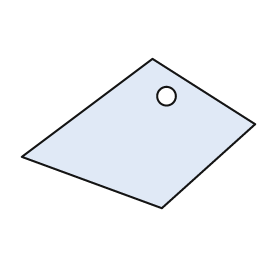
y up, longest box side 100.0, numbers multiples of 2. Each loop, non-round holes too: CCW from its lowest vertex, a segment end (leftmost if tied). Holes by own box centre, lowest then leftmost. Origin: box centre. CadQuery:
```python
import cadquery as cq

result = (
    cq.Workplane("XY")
    .moveTo(10.0, -32.0)
    .lineTo(50.0, 4.0)
    .lineTo(6.0, 32.0)
    .lineTo(-50.0, -10.0)
    .close()
    .moveTo(12.0, 16.0)
    .circle(4.0)
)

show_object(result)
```